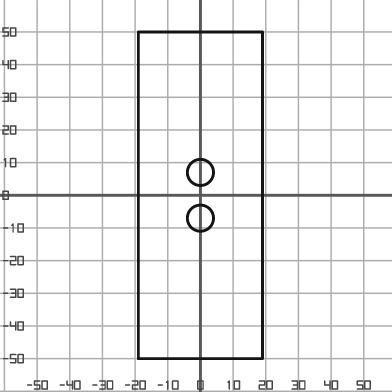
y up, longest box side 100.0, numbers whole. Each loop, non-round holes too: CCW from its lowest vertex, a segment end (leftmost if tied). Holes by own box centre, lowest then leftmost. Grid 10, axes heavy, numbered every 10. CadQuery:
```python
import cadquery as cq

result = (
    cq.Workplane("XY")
    .moveTo(-19.0, -50.0)
    .lineTo(19.0, -50.0)
    .lineTo(19.0, 50.0)
    .lineTo(-19.0, 50.0)
    .close()
    .moveTo(0.0, -7.0)
    .circle(4.0)
    .moveTo(0.0, 7.0)
    .circle(4.0)
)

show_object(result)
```